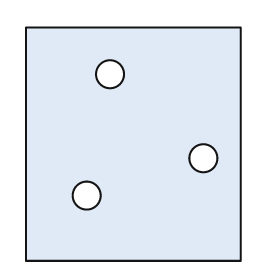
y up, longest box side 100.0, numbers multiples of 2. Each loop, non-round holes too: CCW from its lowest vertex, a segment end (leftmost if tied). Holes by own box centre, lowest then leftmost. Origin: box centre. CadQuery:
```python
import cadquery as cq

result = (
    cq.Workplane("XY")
    .moveTo(-46.0, -50.0)
    .lineTo(46.0, -50.0)
    .lineTo(46.0, 50.0)
    .lineTo(-46.0, 50.0)
    .close()
    .moveTo(-20.0, -22.0)
    .circle(6.0)
    .moveTo(30.0, -6.0)
    .circle(6.0)
    .moveTo(-10.0, 30.0)
    .circle(6.0)
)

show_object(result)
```